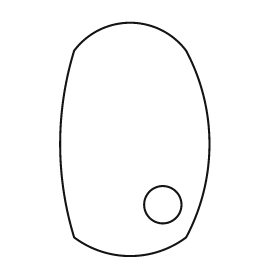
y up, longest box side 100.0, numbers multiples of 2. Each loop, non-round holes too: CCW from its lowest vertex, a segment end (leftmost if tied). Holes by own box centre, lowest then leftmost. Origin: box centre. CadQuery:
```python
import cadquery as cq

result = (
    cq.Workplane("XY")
    .moveTo(-26.0, -42.0)
    .threePointArc((-2.0, -50.0), (22.0, -42.0))
    .threePointArc((32.0, -2.0), (22.0, 38.0))
    .threePointArc((-2.0, 50.0), (-26.0, 38.0))
    .threePointArc((-32.0, -2.0), (-26.0, -42.0))
    .close()
    .moveTo(12.0, -28.0)
    .circle(8.0)
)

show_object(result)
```